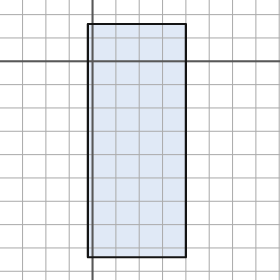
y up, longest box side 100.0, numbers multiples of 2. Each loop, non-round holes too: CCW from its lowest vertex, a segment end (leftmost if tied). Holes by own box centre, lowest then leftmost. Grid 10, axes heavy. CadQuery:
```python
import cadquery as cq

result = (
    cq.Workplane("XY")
    .moveTo(-2.0, -84.0)
    .lineTo(40.0, -84.0)
    .lineTo(40.0, 16.0)
    .lineTo(-2.0, 16.0)
    .close()
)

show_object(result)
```